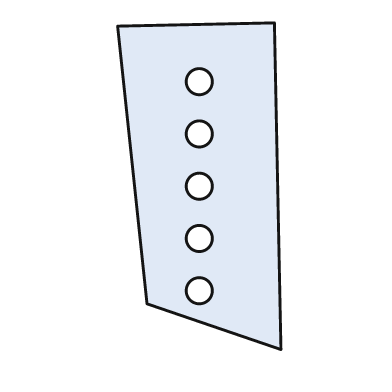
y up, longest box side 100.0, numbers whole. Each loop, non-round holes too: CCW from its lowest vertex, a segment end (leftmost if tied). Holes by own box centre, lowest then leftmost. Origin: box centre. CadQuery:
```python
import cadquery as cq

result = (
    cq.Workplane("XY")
    .moveTo(25.0, -50.0)
    .lineTo(23.0, 50.0)
    .lineTo(-25.0, 49.0)
    .lineTo(-16.0, -36.0)
    .close()
    .moveTo(0.0, -32.0)
    .circle(4.0)
    .moveTo(0.0, -16.0)
    .circle(4.0)
    .moveTo(0.0, 0.0)
    .circle(4.0)
    .moveTo(0.0, 16.0)
    .circle(4.0)
    .moveTo(0.0, 32.0)
    .circle(4.0)
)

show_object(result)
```